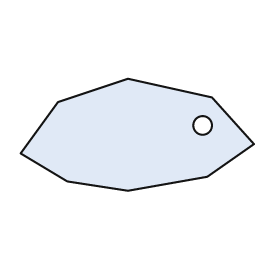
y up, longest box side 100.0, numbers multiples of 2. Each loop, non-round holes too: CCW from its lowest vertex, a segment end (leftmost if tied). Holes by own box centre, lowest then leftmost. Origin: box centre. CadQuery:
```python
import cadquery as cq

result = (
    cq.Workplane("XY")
    .moveTo(-4.0, -24.0)
    .lineTo(30.0, -18.0)
    .lineTo(50.0, -4.0)
    .lineTo(32.0, 16.0)
    .lineTo(-4.0, 24.0)
    .lineTo(-34.0, 14.0)
    .lineTo(-50.0, -8.0)
    .lineTo(-30.0, -20.0)
    .close()
    .moveTo(28.0, 4.0)
    .circle(4.0)
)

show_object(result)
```